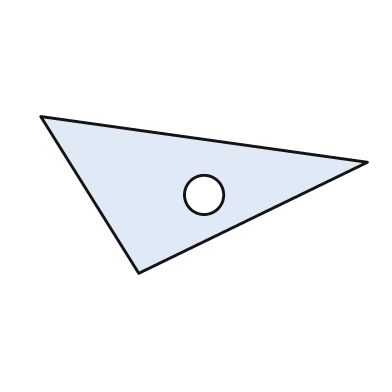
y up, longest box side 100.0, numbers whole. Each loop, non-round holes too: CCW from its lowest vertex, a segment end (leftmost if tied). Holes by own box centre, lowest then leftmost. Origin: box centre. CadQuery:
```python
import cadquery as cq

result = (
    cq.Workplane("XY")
    .moveTo(-20.0, -24.0)
    .lineTo(50.0, 10.0)
    .lineTo(-50.0, 24.0)
    .close()
    .moveTo(0.0, 0.0)
    .circle(6.0)
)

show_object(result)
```